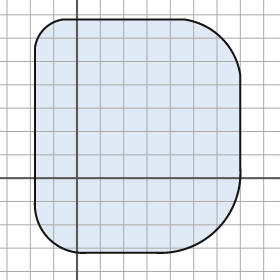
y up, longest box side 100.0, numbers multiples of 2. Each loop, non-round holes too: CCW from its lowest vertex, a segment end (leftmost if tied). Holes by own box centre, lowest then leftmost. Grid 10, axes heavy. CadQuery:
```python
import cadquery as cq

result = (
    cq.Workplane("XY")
    .moveTo(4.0, -32.0)
    .lineTo(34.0, -32.0)
    .threePointArc((60.0, -22.0), (70.0, 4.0))
    .lineTo(70.0, 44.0)
    .threePointArc((62.0, 60.0), (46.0, 68.0))
    .lineTo(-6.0, 68.0)
    .threePointArc((-14.0, 64.0), (-18.0, 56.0))
    .lineTo(-18.0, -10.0)
    .threePointArc((-12.0, -26.0), (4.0, -32.0))
    .close()
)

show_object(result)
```